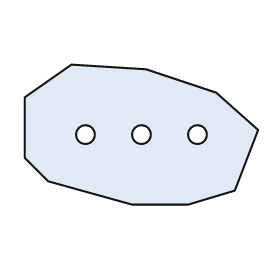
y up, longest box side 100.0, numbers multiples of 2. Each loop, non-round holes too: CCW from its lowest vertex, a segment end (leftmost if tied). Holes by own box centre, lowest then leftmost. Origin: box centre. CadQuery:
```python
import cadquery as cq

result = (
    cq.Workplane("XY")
    .moveTo(-4.0, -30.0)
    .lineTo(20.0, -30.0)
    .lineTo(40.0, -24.0)
    .lineTo(50.0, 2.0)
    .lineTo(32.0, 18.0)
    .lineTo(2.0, 28.0)
    .lineTo(-30.0, 30.0)
    .lineTo(-50.0, 16.0)
    .lineTo(-50.0, -10.0)
    .lineTo(-40.0, -20.0)
    .close()
    .moveTo(-24.0, 0.0)
    .circle(4.0)
    .moveTo(0.0, 0.0)
    .circle(4.0)
    .moveTo(24.0, 0.0)
    .circle(4.0)
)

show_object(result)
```